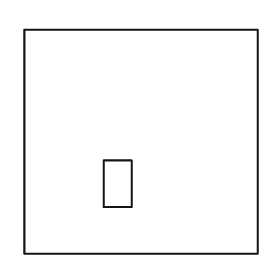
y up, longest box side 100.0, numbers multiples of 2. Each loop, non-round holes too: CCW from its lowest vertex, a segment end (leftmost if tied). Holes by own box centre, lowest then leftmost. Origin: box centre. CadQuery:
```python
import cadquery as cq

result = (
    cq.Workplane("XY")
    .moveTo(-50.0, -48.0)
    .lineTo(50.0, -48.0)
    .lineTo(50.0, 48.0)
    .lineTo(-50.0, 48.0)
    .close()
    .moveTo(-16.0, -28.0)
    .lineTo(-4.0, -28.0)
    .lineTo(-4.0, -8.0)
    .lineTo(-16.0, -8.0)
    .close()
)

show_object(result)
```